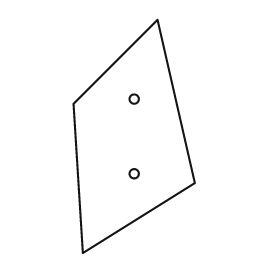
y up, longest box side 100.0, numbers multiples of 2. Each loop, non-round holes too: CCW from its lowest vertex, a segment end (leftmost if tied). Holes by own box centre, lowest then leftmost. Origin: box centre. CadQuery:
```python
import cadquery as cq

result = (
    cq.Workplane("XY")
    .moveTo(-22.0, -50.0)
    .lineTo(26.0, -20.0)
    .lineTo(10.0, 50.0)
    .lineTo(-26.0, 14.0)
    .close()
    .moveTo(0.0, -16.0)
    .circle(2.0)
    .moveTo(0.0, 16.0)
    .circle(2.0)
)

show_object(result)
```